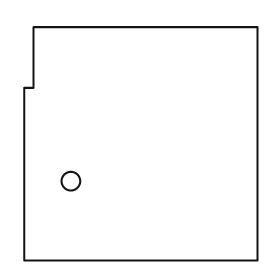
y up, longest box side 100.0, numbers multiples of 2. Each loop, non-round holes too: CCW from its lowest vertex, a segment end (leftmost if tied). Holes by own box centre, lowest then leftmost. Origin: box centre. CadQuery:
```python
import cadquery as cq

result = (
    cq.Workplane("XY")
    .moveTo(-50.0, -50.0)
    .lineTo(50.0, -50.0)
    .lineTo(50.0, 50.0)
    .lineTo(-46.0, 50.0)
    .lineTo(-46.0, 24.0)
    .lineTo(-50.0, 24.0)
    .close()
    .moveTo(-30.0, -16.0)
    .circle(4.0)
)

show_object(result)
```